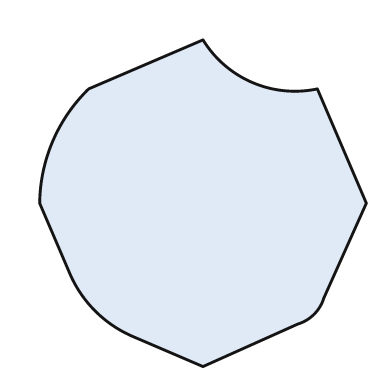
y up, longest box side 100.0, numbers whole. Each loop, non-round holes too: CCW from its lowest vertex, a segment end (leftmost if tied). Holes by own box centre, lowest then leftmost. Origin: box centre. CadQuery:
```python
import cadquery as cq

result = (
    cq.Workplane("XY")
    .moveTo(0.0, -50.0)
    .lineTo(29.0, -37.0)
    .threePointArc((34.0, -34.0), (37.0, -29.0))
    .lineTo(50.0, 0.0)
    .lineTo(35.0, 35.0)
    .threePointArc((15.0, 37.0), (0.0, 50.0))
    .lineTo(-35.0, 35.0)
    .threePointArc((-46.0, 19.0), (-50.0, 0.0))
    .lineTo(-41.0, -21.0)
    .threePointArc((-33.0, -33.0), (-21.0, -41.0))
    .close()
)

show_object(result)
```